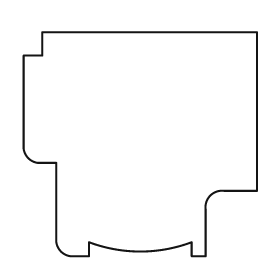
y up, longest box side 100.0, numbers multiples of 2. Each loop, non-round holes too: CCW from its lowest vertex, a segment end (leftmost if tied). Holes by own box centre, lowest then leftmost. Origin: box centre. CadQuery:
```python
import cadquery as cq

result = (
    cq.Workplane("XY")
    .moveTo(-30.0, -48.0)
    .lineTo(-22.0, -48.0)
    .lineTo(-22.0, -42.0)
    .threePointArc((0.0, -46.0), (22.0, -42.0))
    .lineTo(22.0, -48.0)
    .lineTo(28.0, -48.0)
    .lineTo(28.0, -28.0)
    .threePointArc((30.0, -22.0), (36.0, -20.0))
    .lineTo(50.0, -20.0)
    .lineTo(50.0, 48.0)
    .lineTo(-42.0, 48.0)
    .lineTo(-42.0, 38.0)
    .lineTo(-50.0, 38.0)
    .lineTo(-50.0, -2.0)
    .threePointArc((-48.0, -6.0), (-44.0, -8.0))
    .lineTo(-36.0, -8.0)
    .lineTo(-36.0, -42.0)
    .threePointArc((-34.0, -46.0), (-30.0, -48.0))
    .close()
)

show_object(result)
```